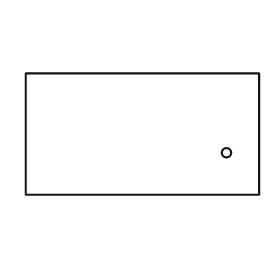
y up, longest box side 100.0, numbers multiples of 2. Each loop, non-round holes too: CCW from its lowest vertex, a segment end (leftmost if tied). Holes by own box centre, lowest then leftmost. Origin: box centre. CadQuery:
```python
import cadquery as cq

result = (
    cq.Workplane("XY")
    .moveTo(-50.0, -26.0)
    .lineTo(50.0, -26.0)
    .lineTo(50.0, 26.0)
    .lineTo(-50.0, 26.0)
    .close()
    .moveTo(36.0, -8.0)
    .circle(2.0)
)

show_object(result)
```